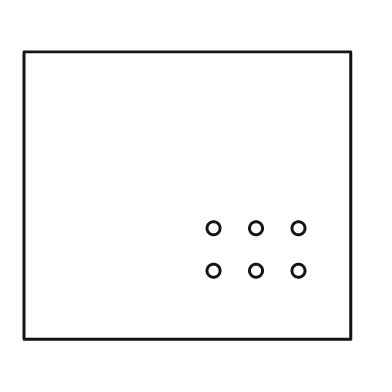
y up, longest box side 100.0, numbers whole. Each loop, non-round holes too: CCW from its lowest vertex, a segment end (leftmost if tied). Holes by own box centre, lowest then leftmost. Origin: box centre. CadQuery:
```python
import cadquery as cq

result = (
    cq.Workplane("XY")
    .moveTo(-50.0, -44.0)
    .lineTo(50.0, -44.0)
    .lineTo(50.0, 44.0)
    .lineTo(-50.0, 44.0)
    .close()
    .moveTo(8.0, -23.0)
    .circle(2.0)
    .moveTo(21.0, -23.0)
    .circle(2.0)
    .moveTo(34.0, -23.0)
    .circle(2.0)
    .moveTo(8.0, -10.0)
    .circle(2.0)
    .moveTo(21.0, -10.0)
    .circle(2.0)
    .moveTo(34.0, -10.0)
    .circle(2.0)
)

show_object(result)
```